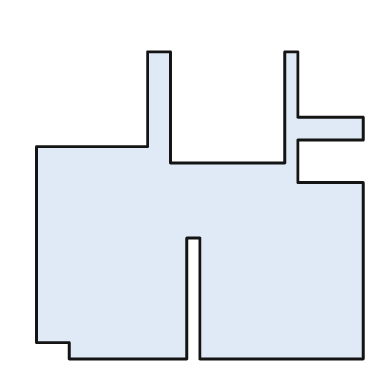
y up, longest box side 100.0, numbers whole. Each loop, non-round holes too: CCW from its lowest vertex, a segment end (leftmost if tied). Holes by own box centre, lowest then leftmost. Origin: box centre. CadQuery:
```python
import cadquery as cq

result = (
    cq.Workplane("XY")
    .moveTo(-40.0, -47.0)
    .lineTo(-4.0, -47.0)
    .lineTo(-4.0, -10.0)
    .lineTo(0.0, -10.0)
    .lineTo(0.0, -47.0)
    .lineTo(50.0, -47.0)
    .lineTo(50.0, 7.0)
    .lineTo(30.0, 7.0)
    .lineTo(30.0, 20.0)
    .lineTo(50.0, 20.0)
    .lineTo(50.0, 27.0)
    .lineTo(30.0, 27.0)
    .lineTo(30.0, 47.0)
    .lineTo(26.0, 47.0)
    .lineTo(26.0, 13.0)
    .lineTo(-9.0, 13.0)
    .lineTo(-9.0, 47.0)
    .lineTo(-16.0, 47.0)
    .lineTo(-16.0, 18.0)
    .lineTo(-50.0, 18.0)
    .lineTo(-50.0, -42.0)
    .lineTo(-40.0, -42.0)
    .close()
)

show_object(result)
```